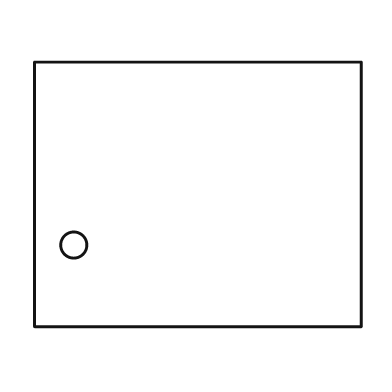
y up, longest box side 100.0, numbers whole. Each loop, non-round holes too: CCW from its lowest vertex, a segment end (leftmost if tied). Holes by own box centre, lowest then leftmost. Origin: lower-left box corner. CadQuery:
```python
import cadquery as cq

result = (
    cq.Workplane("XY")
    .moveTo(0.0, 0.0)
    .lineTo(100.0, 0.0)
    .lineTo(100.0, 81.0)
    .lineTo(0.0, 81.0)
    .close()
    .moveTo(12.0, 25.0)
    .circle(4.0)
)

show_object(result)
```